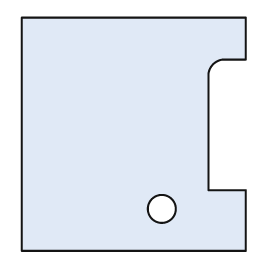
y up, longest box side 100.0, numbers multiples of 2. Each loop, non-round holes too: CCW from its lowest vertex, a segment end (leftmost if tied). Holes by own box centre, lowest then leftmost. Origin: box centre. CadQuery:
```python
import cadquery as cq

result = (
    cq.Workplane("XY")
    .moveTo(-48.0, -50.0)
    .lineTo(48.0, -50.0)
    .lineTo(48.0, -24.0)
    .lineTo(32.0, -24.0)
    .lineTo(32.0, 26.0)
    .threePointArc((34.0, 30.0), (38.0, 32.0))
    .lineTo(48.0, 32.0)
    .lineTo(48.0, 50.0)
    .lineTo(-48.0, 50.0)
    .close()
    .moveTo(12.0, -32.0)
    .circle(6.0)
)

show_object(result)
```